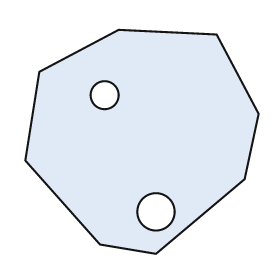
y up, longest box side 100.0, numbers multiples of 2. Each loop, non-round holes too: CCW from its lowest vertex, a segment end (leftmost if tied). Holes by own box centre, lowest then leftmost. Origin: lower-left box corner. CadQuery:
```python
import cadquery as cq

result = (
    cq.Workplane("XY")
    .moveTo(56.0, 0.0)
    .lineTo(94.0, 32.0)
    .lineTo(100.0, 60.0)
    .lineTo(82.0, 94.0)
    .lineTo(40.0, 96.0)
    .lineTo(6.0, 78.0)
    .lineTo(0.0, 40.0)
    .lineTo(32.0, 4.0)
    .close()
    .moveTo(56.0, 18.0)
    .circle(8.0)
    .moveTo(34.0, 68.0)
    .circle(6.0)
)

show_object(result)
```